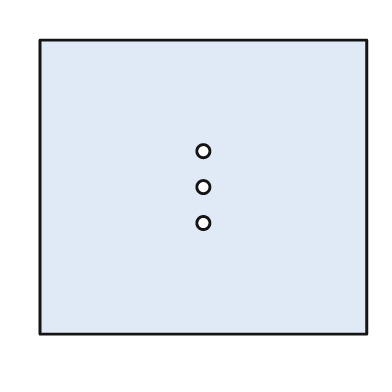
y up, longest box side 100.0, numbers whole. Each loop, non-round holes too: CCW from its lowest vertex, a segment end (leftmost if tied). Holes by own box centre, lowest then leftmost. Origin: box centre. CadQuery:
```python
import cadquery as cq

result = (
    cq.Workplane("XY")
    .moveTo(-50.0, -45.0)
    .lineTo(50.0, -45.0)
    .lineTo(50.0, 45.0)
    .lineTo(-50.0, 45.0)
    .close()
    .moveTo(0.0, -11.0)
    .circle(2.0)
    .moveTo(0.0, 0.0)
    .circle(2.0)
    .moveTo(0.0, 11.0)
    .circle(2.0)
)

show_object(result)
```